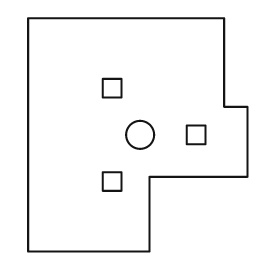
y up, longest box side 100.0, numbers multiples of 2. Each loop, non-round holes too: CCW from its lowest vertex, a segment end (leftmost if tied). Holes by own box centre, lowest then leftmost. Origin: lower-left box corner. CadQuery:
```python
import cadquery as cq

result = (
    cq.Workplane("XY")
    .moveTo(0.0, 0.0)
    .lineTo(52.0, 0.0)
    .lineTo(52.0, 32.0)
    .lineTo(94.0, 32.0)
    .lineTo(94.0, 62.0)
    .lineTo(84.0, 62.0)
    .lineTo(84.0, 100.0)
    .lineTo(0.0, 100.0)
    .close()
    .moveTo(32.0, 26.0)
    .lineTo(40.0, 26.0)
    .lineTo(40.0, 34.0)
    .lineTo(32.0, 34.0)
    .close()
    .moveTo(48.0, 50.0)
    .circle(6.0)
    .moveTo(68.0, 46.0)
    .lineTo(76.0, 46.0)
    .lineTo(76.0, 54.0)
    .lineTo(68.0, 54.0)
    .close()
    .moveTo(32.0, 66.0)
    .lineTo(40.0, 66.0)
    .lineTo(40.0, 74.0)
    .lineTo(32.0, 74.0)
    .close()
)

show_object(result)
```